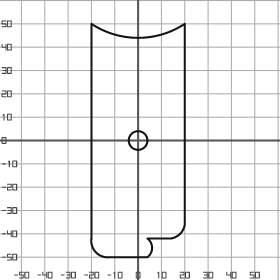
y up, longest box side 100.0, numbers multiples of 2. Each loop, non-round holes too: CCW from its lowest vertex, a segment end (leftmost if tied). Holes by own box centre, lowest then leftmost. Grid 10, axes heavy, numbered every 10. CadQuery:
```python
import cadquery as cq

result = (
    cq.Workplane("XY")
    .moveTo(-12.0, -50.0)
    .lineTo(4.0, -50.0)
    .threePointArc((6.0, -46.0), (4.0, -42.0))
    .lineTo(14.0, -42.0)
    .threePointArc((18.0, -40.0), (20.0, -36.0))
    .lineTo(20.0, 50.0)
    .threePointArc((0.0, 44.0), (-20.0, 50.0))
    .lineTo(-20.0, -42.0)
    .threePointArc((-18.0, -48.0), (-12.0, -50.0))
    .close()
    .moveTo(0.0, 0.0)
    .circle(4.0)
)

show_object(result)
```